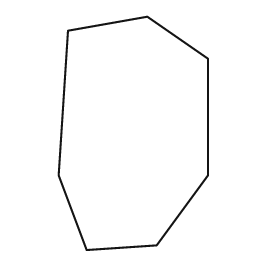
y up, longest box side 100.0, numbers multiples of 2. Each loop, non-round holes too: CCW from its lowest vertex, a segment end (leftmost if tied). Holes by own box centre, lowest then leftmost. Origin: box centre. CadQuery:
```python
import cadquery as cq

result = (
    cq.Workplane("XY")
    .moveTo(-20.0, -50.0)
    .lineTo(10.0, -48.0)
    .lineTo(32.0, -18.0)
    .lineTo(32.0, 32.0)
    .lineTo(6.0, 50.0)
    .lineTo(-28.0, 44.0)
    .lineTo(-32.0, -18.0)
    .close()
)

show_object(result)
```